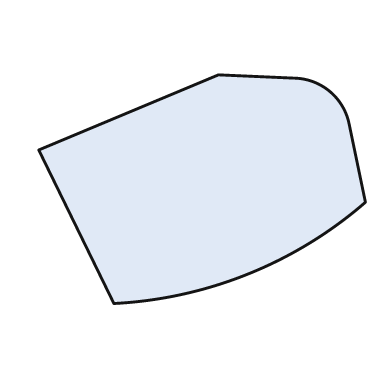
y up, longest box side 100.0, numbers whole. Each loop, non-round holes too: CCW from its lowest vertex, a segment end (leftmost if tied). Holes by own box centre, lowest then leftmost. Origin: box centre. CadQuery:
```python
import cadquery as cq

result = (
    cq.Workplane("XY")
    .moveTo(-27.0, -35.0)
    .threePointArc((14.0, -26.0), (50.0, -4.0))
    .lineTo(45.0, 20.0)
    .threePointArc((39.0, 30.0), (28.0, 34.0))
    .lineTo(5.0, 35.0)
    .lineTo(-50.0, 12.0)
    .close()
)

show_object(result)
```